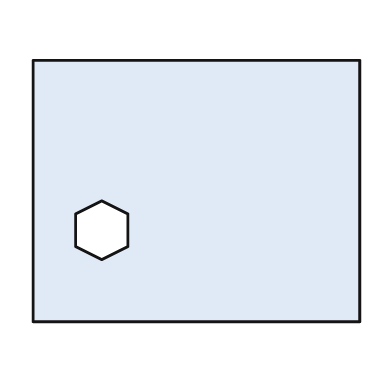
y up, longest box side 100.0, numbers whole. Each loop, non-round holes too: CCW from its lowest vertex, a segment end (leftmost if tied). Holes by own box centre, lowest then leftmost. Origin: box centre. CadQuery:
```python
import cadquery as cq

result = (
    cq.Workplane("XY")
    .moveTo(-50.0, -40.0)
    .lineTo(50.0, -40.0)
    .lineTo(50.0, 40.0)
    .lineTo(-50.0, 40.0)
    .close()
    .moveTo(-29.0, -21.0)
    .lineTo(-21.0, -17.0)
    .lineTo(-21.0, -7.0)
    .lineTo(-29.0, -3.0)
    .lineTo(-37.0, -7.0)
    .lineTo(-37.0, -17.0)
    .close()
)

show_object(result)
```